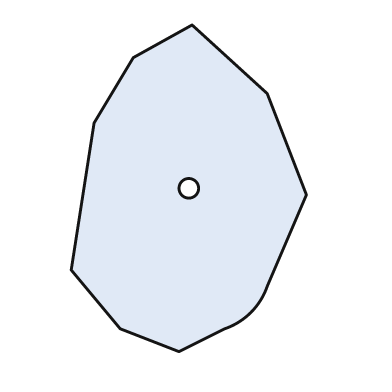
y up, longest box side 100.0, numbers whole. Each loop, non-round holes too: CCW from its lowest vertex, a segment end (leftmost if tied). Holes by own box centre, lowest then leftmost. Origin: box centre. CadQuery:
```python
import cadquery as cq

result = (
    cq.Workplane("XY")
    .moveTo(-3.0, -50.0)
    .lineTo(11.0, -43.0)
    .threePointArc((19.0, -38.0), (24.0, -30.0))
    .lineTo(36.0, -2.0)
    .lineTo(24.0, 29.0)
    .lineTo(1.0, 50.0)
    .lineTo(-17.0, 40.0)
    .lineTo(-29.0, 20.0)
    .lineTo(-36.0, -25.0)
    .lineTo(-21.0, -43.0)
    .close()
    .moveTo(0.0, 0.0)
    .circle(3.0)
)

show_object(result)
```